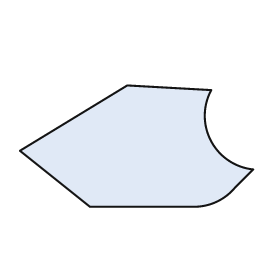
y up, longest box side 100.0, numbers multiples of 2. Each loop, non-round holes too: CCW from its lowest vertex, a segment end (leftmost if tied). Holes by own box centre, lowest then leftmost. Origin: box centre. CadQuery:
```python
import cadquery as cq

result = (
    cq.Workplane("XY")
    .moveTo(-20.0, -26.0)
    .lineTo(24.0, -26.0)
    .threePointArc((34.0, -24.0), (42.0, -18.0))
    .lineTo(50.0, -10.0)
    .threePointArc((32.0, 2.0), (32.0, 24.0))
    .lineTo(-4.0, 26.0)
    .lineTo(-50.0, -2.0)
    .close()
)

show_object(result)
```